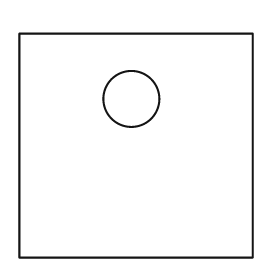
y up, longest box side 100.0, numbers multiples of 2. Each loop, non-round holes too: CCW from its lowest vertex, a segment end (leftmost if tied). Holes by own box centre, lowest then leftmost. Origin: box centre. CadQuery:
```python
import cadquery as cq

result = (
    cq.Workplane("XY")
    .moveTo(-50.0, -48.0)
    .lineTo(50.0, -48.0)
    .lineTo(50.0, 48.0)
    .lineTo(-50.0, 48.0)
    .close()
    .moveTo(-2.0, 20.0)
    .circle(12.0)
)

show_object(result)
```